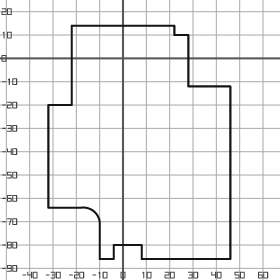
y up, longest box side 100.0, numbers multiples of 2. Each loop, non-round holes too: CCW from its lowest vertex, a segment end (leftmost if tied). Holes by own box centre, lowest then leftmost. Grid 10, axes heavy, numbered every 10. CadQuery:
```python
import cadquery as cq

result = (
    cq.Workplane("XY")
    .moveTo(-10.0, -86.0)
    .lineTo(-4.0, -86.0)
    .lineTo(-4.0, -80.0)
    .lineTo(8.0, -80.0)
    .lineTo(8.0, -86.0)
    .lineTo(46.0, -86.0)
    .lineTo(46.0, -12.0)
    .lineTo(28.0, -12.0)
    .lineTo(28.0, 10.0)
    .lineTo(22.0, 10.0)
    .lineTo(22.0, 14.0)
    .lineTo(-22.0, 14.0)
    .lineTo(-22.0, -20.0)
    .lineTo(-32.0, -20.0)
    .lineTo(-32.0, -64.0)
    .lineTo(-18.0, -64.0)
    .threePointArc((-12.0, -66.0), (-10.0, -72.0))
    .close()
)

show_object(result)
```